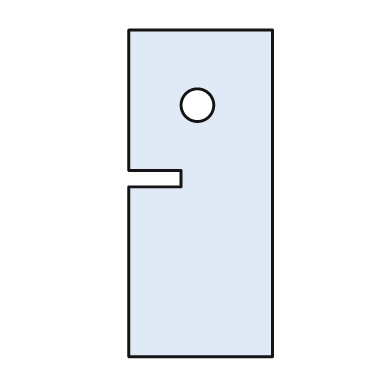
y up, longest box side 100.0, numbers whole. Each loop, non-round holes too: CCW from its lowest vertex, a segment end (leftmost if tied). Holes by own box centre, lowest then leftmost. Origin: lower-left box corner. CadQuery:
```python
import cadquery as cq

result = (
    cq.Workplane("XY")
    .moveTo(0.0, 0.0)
    .lineTo(44.0, 0.0)
    .lineTo(44.0, 100.0)
    .lineTo(0.0, 100.0)
    .lineTo(0.0, 57.0)
    .lineTo(16.0, 57.0)
    .lineTo(16.0, 52.0)
    .lineTo(0.0, 52.0)
    .close()
    .moveTo(21.0, 77.0)
    .circle(5.0)
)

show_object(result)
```